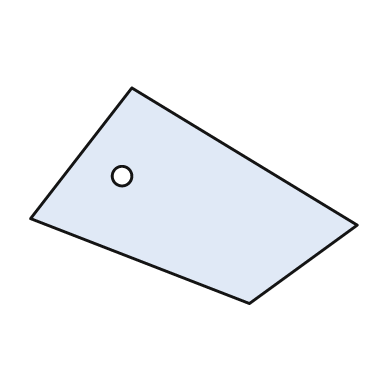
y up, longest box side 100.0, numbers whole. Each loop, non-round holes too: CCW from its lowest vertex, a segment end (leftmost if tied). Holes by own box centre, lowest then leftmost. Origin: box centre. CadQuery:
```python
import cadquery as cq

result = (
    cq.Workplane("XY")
    .moveTo(17.0, -33.0)
    .lineTo(50.0, -9.0)
    .lineTo(-19.0, 33.0)
    .lineTo(-50.0, -7.0)
    .close()
    .moveTo(-22.0, 6.0)
    .circle(3.0)
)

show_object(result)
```